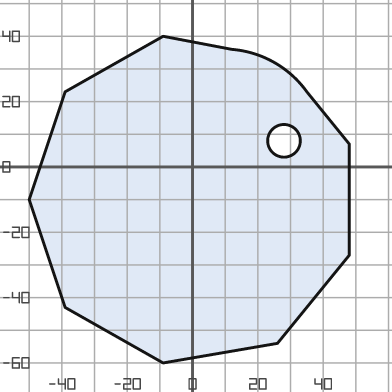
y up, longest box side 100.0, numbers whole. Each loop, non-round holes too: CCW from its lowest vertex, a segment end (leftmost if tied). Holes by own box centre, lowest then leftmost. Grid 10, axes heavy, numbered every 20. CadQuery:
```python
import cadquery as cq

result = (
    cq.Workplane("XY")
    .moveTo(-9.0, -60.0)
    .lineTo(26.0, -54.0)
    .lineTo(48.0, -27.0)
    .lineTo(48.0, 7.0)
    .lineTo(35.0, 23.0)
    .threePointArc((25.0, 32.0), (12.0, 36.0))
    .lineTo(-9.0, 40.0)
    .lineTo(-39.0, 23.0)
    .lineTo(-50.0, -10.0)
    .lineTo(-39.0, -43.0)
    .close()
    .moveTo(28.0, 8.0)
    .circle(5.0)
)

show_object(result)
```